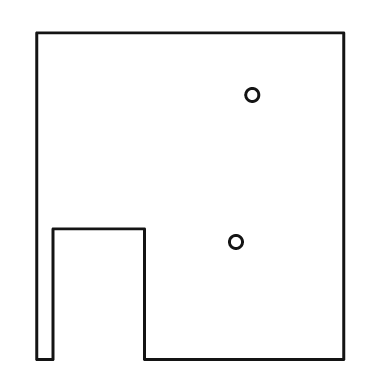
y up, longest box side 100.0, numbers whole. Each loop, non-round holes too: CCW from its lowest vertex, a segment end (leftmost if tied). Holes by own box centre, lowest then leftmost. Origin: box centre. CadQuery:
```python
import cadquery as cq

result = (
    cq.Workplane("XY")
    .moveTo(-47.0, -50.0)
    .lineTo(-42.0, -50.0)
    .lineTo(-42.0, -10.0)
    .lineTo(-14.0, -10.0)
    .lineTo(-14.0, -50.0)
    .lineTo(47.0, -50.0)
    .lineTo(47.0, 50.0)
    .lineTo(-47.0, 50.0)
    .close()
    .moveTo(14.0, -14.0)
    .circle(2.0)
    .moveTo(19.0, 31.0)
    .circle(2.0)
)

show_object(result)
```